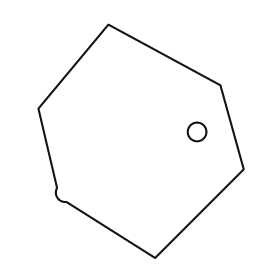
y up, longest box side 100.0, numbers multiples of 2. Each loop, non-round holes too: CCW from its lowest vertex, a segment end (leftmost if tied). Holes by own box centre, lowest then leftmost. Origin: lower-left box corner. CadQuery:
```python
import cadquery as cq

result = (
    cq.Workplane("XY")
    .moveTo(50.0, 0.0)
    .lineTo(88.0, 38.0)
    .lineTo(78.0, 74.0)
    .lineTo(30.0, 100.0)
    .lineTo(0.0, 64.0)
    .lineTo(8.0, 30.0)
    .threePointArc((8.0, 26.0), (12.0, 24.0))
    .close()
    .moveTo(68.0, 54.0)
    .circle(4.0)
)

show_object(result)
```